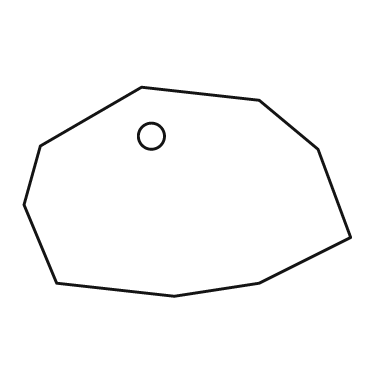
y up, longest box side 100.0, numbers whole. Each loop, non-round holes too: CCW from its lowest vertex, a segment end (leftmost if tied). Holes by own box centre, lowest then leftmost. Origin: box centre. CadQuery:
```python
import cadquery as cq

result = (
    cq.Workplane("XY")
    .moveTo(-4.0, -32.0)
    .lineTo(22.0, -28.0)
    .lineTo(50.0, -14.0)
    .lineTo(40.0, 13.0)
    .lineTo(22.0, 28.0)
    .lineTo(-14.0, 32.0)
    .lineTo(-45.0, 14.0)
    .lineTo(-50.0, -4.0)
    .lineTo(-40.0, -28.0)
    .close()
    .moveTo(-11.0, 17.0)
    .circle(4.0)
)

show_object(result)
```